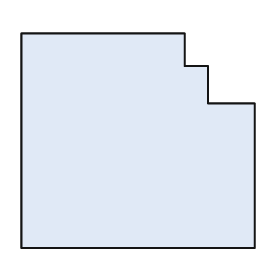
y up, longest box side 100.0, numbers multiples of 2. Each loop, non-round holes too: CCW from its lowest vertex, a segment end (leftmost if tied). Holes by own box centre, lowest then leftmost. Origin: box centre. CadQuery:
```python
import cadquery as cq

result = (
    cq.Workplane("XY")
    .moveTo(-50.0, -46.0)
    .lineTo(50.0, -46.0)
    .lineTo(50.0, 16.0)
    .lineTo(30.0, 16.0)
    .lineTo(30.0, 32.0)
    .lineTo(20.0, 32.0)
    .lineTo(20.0, 46.0)
    .lineTo(-50.0, 46.0)
    .close()
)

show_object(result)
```